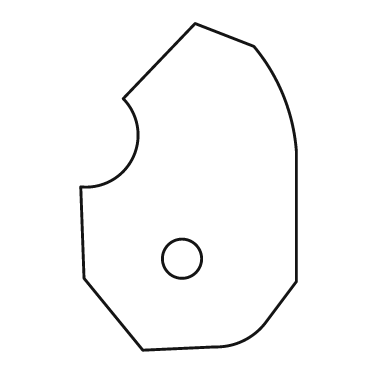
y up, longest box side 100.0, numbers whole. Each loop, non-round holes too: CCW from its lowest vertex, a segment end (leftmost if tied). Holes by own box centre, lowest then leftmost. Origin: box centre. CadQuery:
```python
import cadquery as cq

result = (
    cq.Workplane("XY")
    .moveTo(-14.0, -50.0)
    .lineTo(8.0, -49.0)
    .threePointArc((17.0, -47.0), (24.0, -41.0))
    .lineTo(33.0, -29.0)
    .lineTo(33.0, 11.0)
    .threePointArc((29.0, 28.0), (20.0, 43.0))
    .lineTo(2.0, 50.0)
    .lineTo(-20.0, 27.0)
    .threePointArc((-17.0, 9.0), (-33.0, 0.0))
    .lineTo(-32.0, -28.0)
    .close()
    .moveTo(-2.0, -22.0)
    .circle(6.0)
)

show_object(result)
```